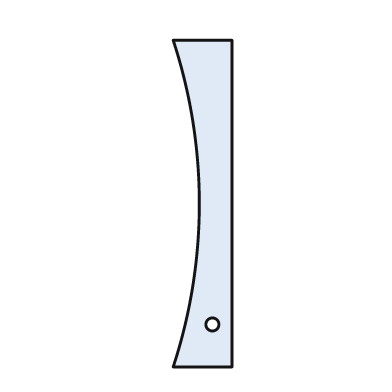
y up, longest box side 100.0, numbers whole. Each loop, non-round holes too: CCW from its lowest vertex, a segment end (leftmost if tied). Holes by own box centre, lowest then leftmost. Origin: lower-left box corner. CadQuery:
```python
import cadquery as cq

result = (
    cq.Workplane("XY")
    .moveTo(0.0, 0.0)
    .lineTo(18.0, 0.0)
    .lineTo(18.0, 100.0)
    .lineTo(0.0, 100.0)
    .threePointArc((8.0, 50.0), (0.0, 0.0))
    .close()
    .moveTo(12.0, 13.0)
    .circle(2.0)
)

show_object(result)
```